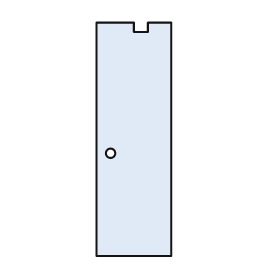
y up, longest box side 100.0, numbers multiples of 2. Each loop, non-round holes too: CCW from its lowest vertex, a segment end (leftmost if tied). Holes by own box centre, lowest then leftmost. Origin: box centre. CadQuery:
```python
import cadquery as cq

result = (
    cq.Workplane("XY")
    .moveTo(-16.0, -50.0)
    .lineTo(16.0, -50.0)
    .lineTo(16.0, 50.0)
    .lineTo(6.0, 50.0)
    .lineTo(6.0, 46.0)
    .lineTo(0.0, 46.0)
    .lineTo(0.0, 50.0)
    .lineTo(-16.0, 50.0)
    .close()
    .moveTo(-10.0, -6.0)
    .circle(2.0)
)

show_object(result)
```